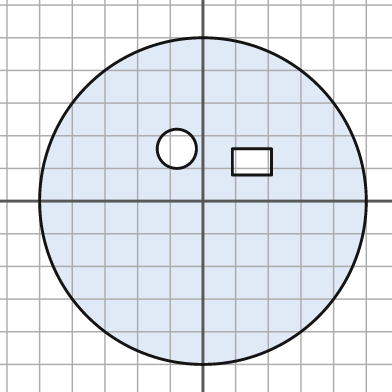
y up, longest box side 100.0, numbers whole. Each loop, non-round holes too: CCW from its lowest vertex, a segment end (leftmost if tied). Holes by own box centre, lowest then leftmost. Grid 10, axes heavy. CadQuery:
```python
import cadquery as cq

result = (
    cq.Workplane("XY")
    .moveTo(0.0, 0.0)
    .circle(50.0)
    .moveTo(9.0, 8.0)
    .lineTo(21.0, 8.0)
    .lineTo(21.0, 16.0)
    .lineTo(9.0, 16.0)
    .close()
    .moveTo(-8.0, 16.0)
    .circle(6.0)
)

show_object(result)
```